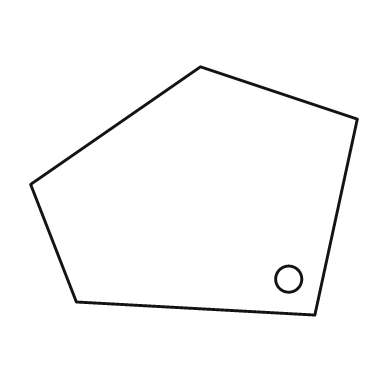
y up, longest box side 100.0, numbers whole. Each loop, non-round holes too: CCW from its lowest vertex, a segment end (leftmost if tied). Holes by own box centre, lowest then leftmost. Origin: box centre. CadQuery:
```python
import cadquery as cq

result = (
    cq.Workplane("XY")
    .moveTo(37.0, -38.0)
    .lineTo(50.0, 22.0)
    .lineTo(2.0, 38.0)
    .lineTo(-50.0, 2.0)
    .lineTo(-36.0, -34.0)
    .close()
    .moveTo(29.0, -27.0)
    .circle(4.0)
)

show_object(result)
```